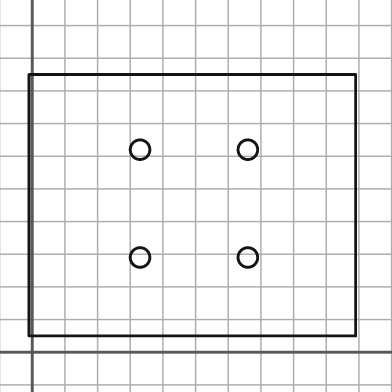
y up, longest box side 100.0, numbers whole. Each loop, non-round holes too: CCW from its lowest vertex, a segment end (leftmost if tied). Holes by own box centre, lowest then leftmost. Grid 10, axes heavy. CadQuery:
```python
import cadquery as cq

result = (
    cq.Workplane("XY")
    .moveTo(-1.0, 5.0)
    .lineTo(99.0, 5.0)
    .lineTo(99.0, 85.0)
    .lineTo(-1.0, 85.0)
    .close()
    .moveTo(33.0, 29.0)
    .circle(3.0)
    .moveTo(66.0, 29.0)
    .circle(3.0)
    .moveTo(33.0, 62.0)
    .circle(3.0)
    .moveTo(66.0, 62.0)
    .circle(3.0)
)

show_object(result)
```